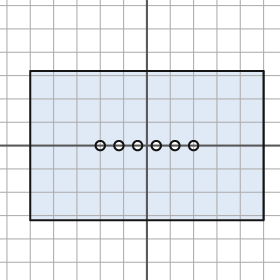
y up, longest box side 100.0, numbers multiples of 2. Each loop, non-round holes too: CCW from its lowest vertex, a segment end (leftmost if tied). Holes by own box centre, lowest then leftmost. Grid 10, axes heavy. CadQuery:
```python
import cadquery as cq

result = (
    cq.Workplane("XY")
    .moveTo(-50.0, -32.0)
    .lineTo(50.0, -32.0)
    .lineTo(50.0, 32.0)
    .lineTo(-50.0, 32.0)
    .close()
    .moveTo(-20.0, 0.0)
    .circle(2.0)
    .moveTo(-12.0, 0.0)
    .circle(2.0)
    .moveTo(-4.0, 0.0)
    .circle(2.0)
    .moveTo(4.0, 0.0)
    .circle(2.0)
    .moveTo(12.0, 0.0)
    .circle(2.0)
    .moveTo(20.0, 0.0)
    .circle(2.0)
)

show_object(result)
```